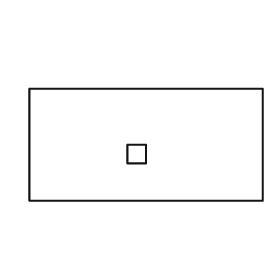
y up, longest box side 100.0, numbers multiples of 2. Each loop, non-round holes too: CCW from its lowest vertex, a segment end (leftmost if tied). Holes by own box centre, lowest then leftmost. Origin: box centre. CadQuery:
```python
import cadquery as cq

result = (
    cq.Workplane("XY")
    .moveTo(-50.0, -24.0)
    .lineTo(50.0, -24.0)
    .lineTo(50.0, 24.0)
    .lineTo(-50.0, 24.0)
    .close()
    .moveTo(-8.0, -8.0)
    .lineTo(0.0, -8.0)
    .lineTo(0.0, 0.0)
    .lineTo(-8.0, 0.0)
    .close()
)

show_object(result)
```